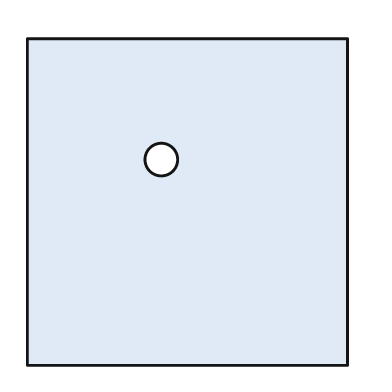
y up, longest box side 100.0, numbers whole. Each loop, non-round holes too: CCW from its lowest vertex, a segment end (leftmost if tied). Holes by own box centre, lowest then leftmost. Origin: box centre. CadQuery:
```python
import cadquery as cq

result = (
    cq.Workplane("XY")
    .moveTo(-49.0, -50.0)
    .lineTo(49.0, -50.0)
    .lineTo(49.0, 50.0)
    .lineTo(-49.0, 50.0)
    .close()
    .moveTo(-8.0, 13.0)
    .circle(5.0)
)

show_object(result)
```